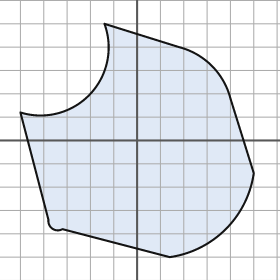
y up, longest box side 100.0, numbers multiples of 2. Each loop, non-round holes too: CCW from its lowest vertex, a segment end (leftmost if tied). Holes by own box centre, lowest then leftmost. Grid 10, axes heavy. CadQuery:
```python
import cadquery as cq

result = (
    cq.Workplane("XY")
    .moveTo(14.0, -50.0)
    .threePointArc((38.0, -38.0), (50.0, -14.0))
    .lineTo(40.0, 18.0)
    .threePointArc((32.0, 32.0), (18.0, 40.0))
    .lineTo(-14.0, 50.0)
    .threePointArc((-20.0, 20.0), (-50.0, 12.0))
    .lineTo(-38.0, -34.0)
    .threePointArc((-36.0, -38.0), (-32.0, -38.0))
    .close()
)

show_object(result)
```